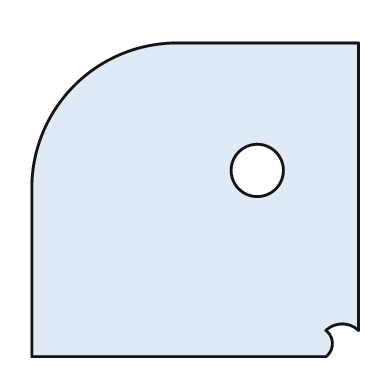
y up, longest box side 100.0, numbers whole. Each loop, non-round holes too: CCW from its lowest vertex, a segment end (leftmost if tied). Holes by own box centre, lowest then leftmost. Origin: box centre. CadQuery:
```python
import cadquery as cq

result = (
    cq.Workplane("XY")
    .moveTo(-50.0, -48.0)
    .lineTo(40.0, -48.0)
    .threePointArc((42.0, -44.0), (40.0, -40.0))
    .threePointArc((45.0, -38.0), (50.0, -40.0))
    .lineTo(50.0, 48.0)
    .lineTo(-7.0, 48.0)
    .threePointArc((-37.0, 35.0), (-50.0, 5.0))
    .close()
    .moveTo(19.0, 9.0)
    .circle(8.0)
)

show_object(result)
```